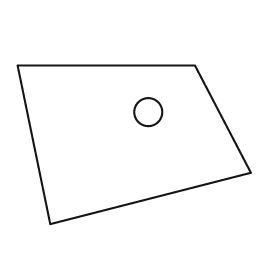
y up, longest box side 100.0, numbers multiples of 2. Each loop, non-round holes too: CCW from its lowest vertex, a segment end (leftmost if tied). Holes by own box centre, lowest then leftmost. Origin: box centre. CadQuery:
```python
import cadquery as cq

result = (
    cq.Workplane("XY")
    .moveTo(-36.0, -34.0)
    .lineTo(50.0, -12.0)
    .lineTo(26.0, 34.0)
    .lineTo(-50.0, 34.0)
    .close()
    .moveTo(6.0, 14.0)
    .circle(6.0)
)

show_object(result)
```